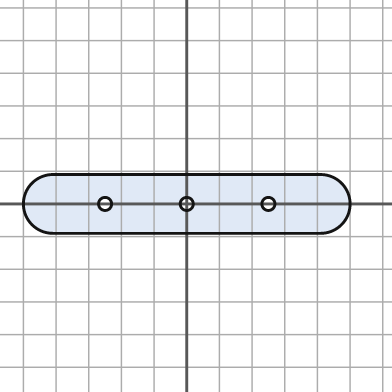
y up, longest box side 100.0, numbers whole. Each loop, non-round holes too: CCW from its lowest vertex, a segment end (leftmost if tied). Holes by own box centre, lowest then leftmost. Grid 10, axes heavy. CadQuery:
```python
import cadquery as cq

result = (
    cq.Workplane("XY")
    .moveTo(-41.0, -9.0)
    .lineTo(41.0, -9.0)
    .threePointArc((50.0, 0.0), (41.0, 9.0))
    .lineTo(-41.0, 9.0)
    .threePointArc((-50.0, 0.0), (-41.0, -9.0))
    .close()
    .moveTo(-25.0, 0.0)
    .circle(2.0)
    .moveTo(0.0, 0.0)
    .circle(2.0)
    .moveTo(25.0, 0.0)
    .circle(2.0)
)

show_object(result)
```